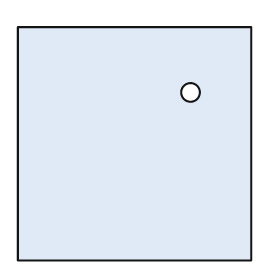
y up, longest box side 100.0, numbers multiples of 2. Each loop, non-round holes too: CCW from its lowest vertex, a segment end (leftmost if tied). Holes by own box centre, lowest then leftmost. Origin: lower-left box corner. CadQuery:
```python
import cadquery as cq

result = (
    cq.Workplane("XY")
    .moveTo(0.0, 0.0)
    .lineTo(100.0, 0.0)
    .lineTo(100.0, 100.0)
    .lineTo(0.0, 100.0)
    .close()
    .moveTo(74.0, 72.0)
    .circle(4.0)
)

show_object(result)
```